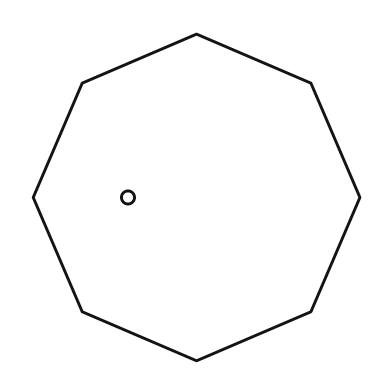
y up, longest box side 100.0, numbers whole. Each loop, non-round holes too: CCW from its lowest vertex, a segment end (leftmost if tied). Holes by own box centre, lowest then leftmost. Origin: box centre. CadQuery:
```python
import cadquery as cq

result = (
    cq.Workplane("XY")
    .moveTo(0.0, -50.0)
    .lineTo(35.0, -35.0)
    .lineTo(50.0, 0.0)
    .lineTo(35.0, 35.0)
    .lineTo(0.0, 50.0)
    .lineTo(-35.0, 35.0)
    .lineTo(-50.0, 0.0)
    .lineTo(-35.0, -35.0)
    .close()
    .moveTo(-21.0, 0.0)
    .circle(2.0)
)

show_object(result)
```